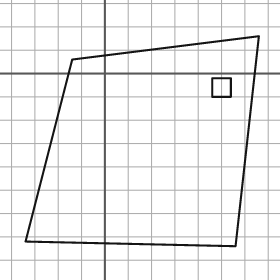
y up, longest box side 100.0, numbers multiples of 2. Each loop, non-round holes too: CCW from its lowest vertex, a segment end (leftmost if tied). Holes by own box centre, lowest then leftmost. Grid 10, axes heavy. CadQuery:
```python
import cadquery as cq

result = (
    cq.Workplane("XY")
    .moveTo(56.0, -74.0)
    .lineTo(66.0, 16.0)
    .lineTo(-14.0, 6.0)
    .lineTo(-34.0, -72.0)
    .close()
    .moveTo(46.0, -10.0)
    .lineTo(54.0, -10.0)
    .lineTo(54.0, -2.0)
    .lineTo(46.0, -2.0)
    .close()
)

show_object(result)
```